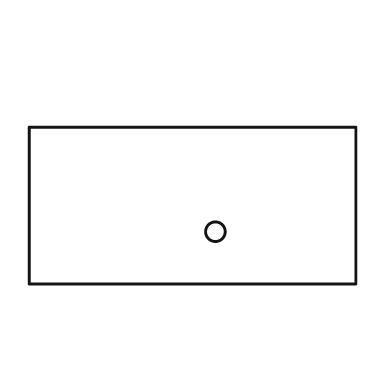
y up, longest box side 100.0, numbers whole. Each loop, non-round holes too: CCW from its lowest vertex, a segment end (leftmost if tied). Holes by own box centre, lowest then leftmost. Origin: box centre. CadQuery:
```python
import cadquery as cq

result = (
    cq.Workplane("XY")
    .moveTo(-50.0, -24.0)
    .lineTo(50.0, -24.0)
    .lineTo(50.0, 24.0)
    .lineTo(-50.0, 24.0)
    .close()
    .moveTo(7.0, -8.0)
    .circle(3.0)
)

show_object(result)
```